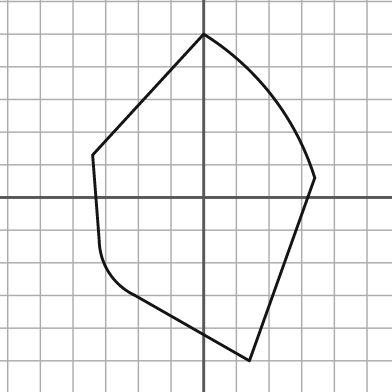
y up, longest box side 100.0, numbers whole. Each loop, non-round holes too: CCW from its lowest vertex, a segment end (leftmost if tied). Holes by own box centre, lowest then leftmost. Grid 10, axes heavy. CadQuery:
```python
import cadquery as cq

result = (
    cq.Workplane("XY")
    .moveTo(14.0, -50.0)
    .lineTo(34.0, 6.0)
    .threePointArc((21.0, 31.0), (0.0, 50.0))
    .lineTo(-34.0, 13.0)
    .lineTo(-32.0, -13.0)
    .threePointArc((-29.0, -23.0), (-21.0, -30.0))
    .close()
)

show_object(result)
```